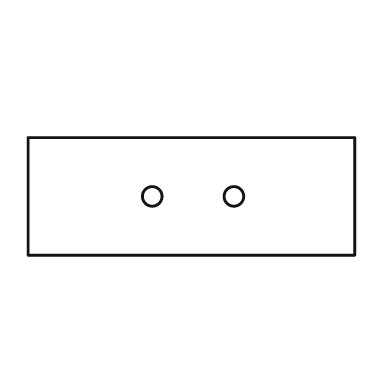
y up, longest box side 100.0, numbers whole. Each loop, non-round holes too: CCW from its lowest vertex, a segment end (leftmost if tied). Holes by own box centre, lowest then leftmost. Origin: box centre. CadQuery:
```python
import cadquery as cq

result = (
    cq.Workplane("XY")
    .moveTo(-50.0, -18.0)
    .lineTo(50.0, -18.0)
    .lineTo(50.0, 18.0)
    .lineTo(-50.0, 18.0)
    .close()
    .moveTo(-12.0, 0.0)
    .circle(3.0)
    .moveTo(13.0, 0.0)
    .circle(3.0)
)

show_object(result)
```